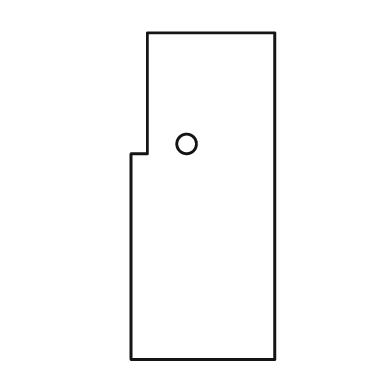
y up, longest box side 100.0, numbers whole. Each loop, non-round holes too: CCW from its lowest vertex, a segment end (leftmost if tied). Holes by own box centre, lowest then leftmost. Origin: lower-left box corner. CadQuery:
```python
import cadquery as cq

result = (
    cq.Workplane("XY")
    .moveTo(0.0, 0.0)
    .lineTo(44.0, 0.0)
    .lineTo(44.0, 100.0)
    .lineTo(5.0, 100.0)
    .lineTo(5.0, 63.0)
    .lineTo(0.0, 63.0)
    .close()
    .moveTo(17.0, 66.0)
    .circle(3.0)
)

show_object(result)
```